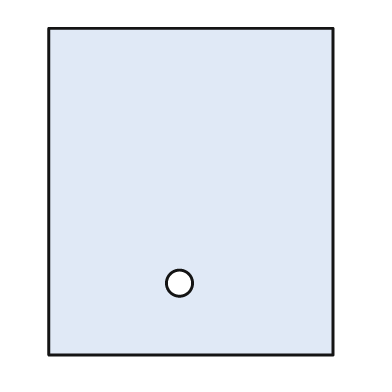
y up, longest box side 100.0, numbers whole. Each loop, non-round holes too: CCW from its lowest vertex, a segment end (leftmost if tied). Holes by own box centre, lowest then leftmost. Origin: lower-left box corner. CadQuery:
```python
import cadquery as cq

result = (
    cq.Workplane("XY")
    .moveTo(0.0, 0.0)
    .lineTo(87.0, 0.0)
    .lineTo(87.0, 100.0)
    .lineTo(0.0, 100.0)
    .close()
    .moveTo(40.0, 22.0)
    .circle(4.0)
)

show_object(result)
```